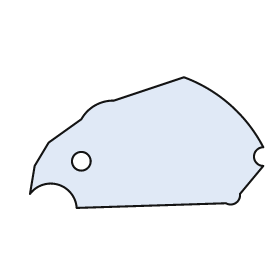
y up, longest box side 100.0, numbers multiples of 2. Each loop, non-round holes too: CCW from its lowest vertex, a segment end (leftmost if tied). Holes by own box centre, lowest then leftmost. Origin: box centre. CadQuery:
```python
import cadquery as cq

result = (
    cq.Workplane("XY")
    .moveTo(-30.0, -28.0)
    .lineTo(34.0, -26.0)
    .threePointArc((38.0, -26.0), (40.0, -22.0))
    .lineTo(50.0, -10.0)
    .threePointArc((46.0, -6.0), (50.0, -2.0))
    .threePointArc((36.0, 16.0), (16.0, 28.0))
    .lineTo(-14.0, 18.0)
    .threePointArc((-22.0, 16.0), (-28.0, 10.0))
    .lineTo(-42.0, 0.0)
    .lineTo(-48.0, -10.0)
    .lineTo(-50.0, -22.0)
    .threePointArc((-38.0, -18.0), (-30.0, -28.0))
    .close()
    .moveTo(-28.0, -8.0)
    .circle(4.0)
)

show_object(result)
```